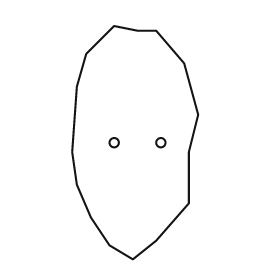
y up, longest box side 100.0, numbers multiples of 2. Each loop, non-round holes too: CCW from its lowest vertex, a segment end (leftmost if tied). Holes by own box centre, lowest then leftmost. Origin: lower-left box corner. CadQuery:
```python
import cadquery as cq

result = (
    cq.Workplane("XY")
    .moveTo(26.0, 0.0)
    .lineTo(36.0, 8.0)
    .lineTo(50.0, 24.0)
    .lineTo(50.0, 46.0)
    .lineTo(54.0, 62.0)
    .lineTo(48.0, 84.0)
    .lineTo(36.0, 98.0)
    .lineTo(28.0, 98.0)
    .lineTo(18.0, 100.0)
    .lineTo(6.0, 88.0)
    .lineTo(2.0, 74.0)
    .lineTo(0.0, 46.0)
    .lineTo(2.0, 32.0)
    .lineTo(8.0, 18.0)
    .lineTo(16.0, 6.0)
    .close()
    .moveTo(18.0, 50.0)
    .circle(2.0)
    .moveTo(38.0, 50.0)
    .circle(2.0)
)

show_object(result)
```